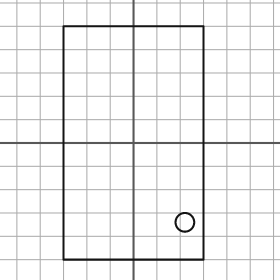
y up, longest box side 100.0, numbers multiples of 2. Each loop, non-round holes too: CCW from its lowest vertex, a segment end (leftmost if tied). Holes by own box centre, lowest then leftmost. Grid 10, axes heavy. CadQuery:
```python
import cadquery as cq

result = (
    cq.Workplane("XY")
    .moveTo(-30.0, -50.0)
    .lineTo(30.0, -50.0)
    .lineTo(30.0, 50.0)
    .lineTo(-30.0, 50.0)
    .close()
    .moveTo(22.0, -34.0)
    .circle(4.0)
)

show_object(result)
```